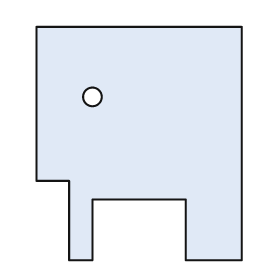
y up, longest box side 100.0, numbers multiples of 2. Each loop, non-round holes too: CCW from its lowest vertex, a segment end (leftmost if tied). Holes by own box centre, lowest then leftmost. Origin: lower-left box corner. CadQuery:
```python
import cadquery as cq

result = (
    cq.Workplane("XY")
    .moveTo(14.0, 0.0)
    .lineTo(24.0, 0.0)
    .lineTo(24.0, 26.0)
    .lineTo(64.0, 26.0)
    .lineTo(64.0, 0.0)
    .lineTo(88.0, 0.0)
    .lineTo(88.0, 100.0)
    .lineTo(0.0, 100.0)
    .lineTo(0.0, 34.0)
    .lineTo(14.0, 34.0)
    .close()
    .moveTo(24.0, 70.0)
    .circle(4.0)
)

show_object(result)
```